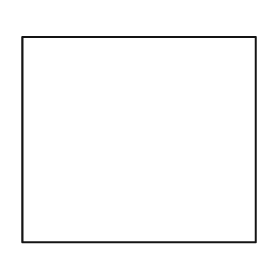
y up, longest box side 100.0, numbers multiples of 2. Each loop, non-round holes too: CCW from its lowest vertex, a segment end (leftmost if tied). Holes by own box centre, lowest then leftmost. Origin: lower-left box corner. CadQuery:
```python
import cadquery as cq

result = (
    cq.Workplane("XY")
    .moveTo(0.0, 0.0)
    .lineTo(100.0, 0.0)
    .lineTo(100.0, 88.0)
    .lineTo(0.0, 88.0)
    .close()
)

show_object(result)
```